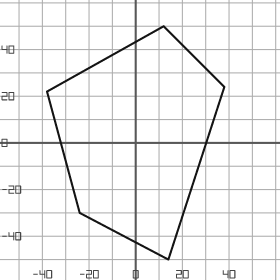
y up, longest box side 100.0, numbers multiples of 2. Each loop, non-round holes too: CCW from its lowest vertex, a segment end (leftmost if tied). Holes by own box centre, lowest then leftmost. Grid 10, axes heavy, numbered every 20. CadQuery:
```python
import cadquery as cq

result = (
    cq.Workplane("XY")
    .moveTo(14.0, -50.0)
    .lineTo(38.0, 24.0)
    .lineTo(12.0, 50.0)
    .lineTo(-38.0, 22.0)
    .lineTo(-24.0, -30.0)
    .close()
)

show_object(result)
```